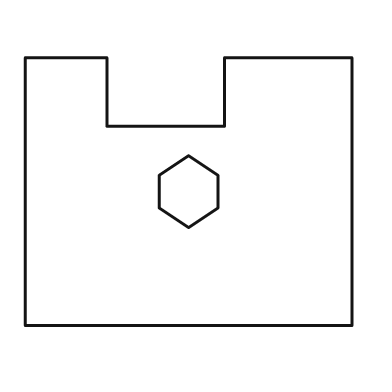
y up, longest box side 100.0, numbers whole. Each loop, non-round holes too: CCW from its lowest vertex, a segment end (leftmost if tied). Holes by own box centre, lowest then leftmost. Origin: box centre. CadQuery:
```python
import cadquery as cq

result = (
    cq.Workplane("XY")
    .moveTo(-50.0, -41.0)
    .lineTo(50.0, -41.0)
    .lineTo(50.0, 41.0)
    .lineTo(11.0, 41.0)
    .lineTo(11.0, 20.0)
    .lineTo(-25.0, 20.0)
    .lineTo(-25.0, 41.0)
    .lineTo(-50.0, 41.0)
    .close()
    .moveTo(0.0, -11.0)
    .lineTo(9.0, -5.0)
    .lineTo(9.0, 5.0)
    .lineTo(0.0, 11.0)
    .lineTo(-9.0, 5.0)
    .lineTo(-9.0, -5.0)
    .close()
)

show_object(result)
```